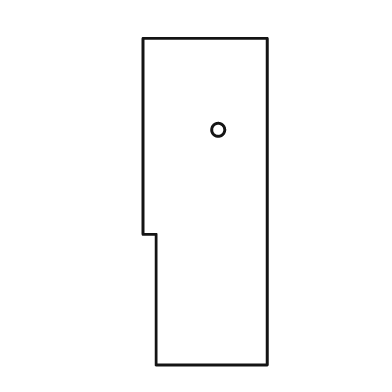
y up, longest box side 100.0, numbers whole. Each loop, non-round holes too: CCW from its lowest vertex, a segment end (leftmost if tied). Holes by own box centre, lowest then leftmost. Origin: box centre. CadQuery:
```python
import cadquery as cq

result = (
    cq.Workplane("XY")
    .moveTo(-15.0, -50.0)
    .lineTo(19.0, -50.0)
    .lineTo(19.0, 50.0)
    .lineTo(-19.0, 50.0)
    .lineTo(-19.0, -10.0)
    .lineTo(-15.0, -10.0)
    .close()
    .moveTo(4.0, 22.0)
    .circle(2.0)
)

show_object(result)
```